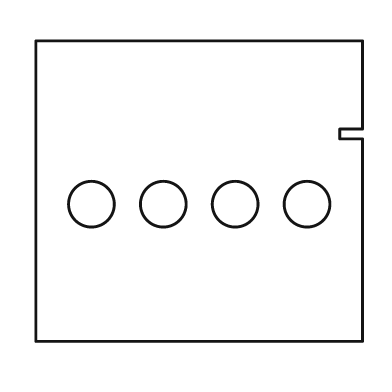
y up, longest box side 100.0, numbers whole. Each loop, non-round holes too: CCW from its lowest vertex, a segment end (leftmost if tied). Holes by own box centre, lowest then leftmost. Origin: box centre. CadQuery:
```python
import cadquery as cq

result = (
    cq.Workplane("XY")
    .moveTo(-50.0, -46.0)
    .lineTo(50.0, -46.0)
    .lineTo(50.0, 16.0)
    .lineTo(43.0, 16.0)
    .lineTo(43.0, 19.0)
    .lineTo(50.0, 19.0)
    .lineTo(50.0, 46.0)
    .lineTo(-50.0, 46.0)
    .close()
    .moveTo(-33.0, -4.0)
    .circle(7.0)
    .moveTo(-11.0, -4.0)
    .circle(7.0)
    .moveTo(11.0, -4.0)
    .circle(7.0)
    .moveTo(33.0, -4.0)
    .circle(7.0)
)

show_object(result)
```